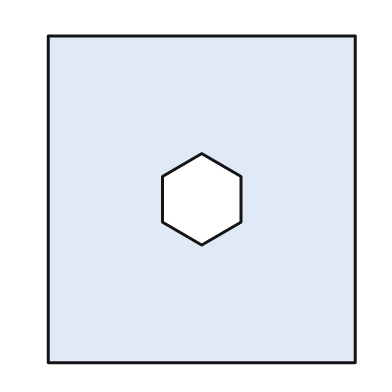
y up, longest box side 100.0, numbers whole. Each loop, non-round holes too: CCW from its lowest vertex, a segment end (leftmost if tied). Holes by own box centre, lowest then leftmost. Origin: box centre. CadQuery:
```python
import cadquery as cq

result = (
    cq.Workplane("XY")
    .moveTo(-47.0, -50.0)
    .lineTo(47.0, -50.0)
    .lineTo(47.0, 50.0)
    .lineTo(-47.0, 50.0)
    .close()
    .moveTo(0.0, -14.0)
    .lineTo(12.0, -7.0)
    .lineTo(12.0, 7.0)
    .lineTo(0.0, 14.0)
    .lineTo(-12.0, 7.0)
    .lineTo(-12.0, -7.0)
    .close()
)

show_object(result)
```